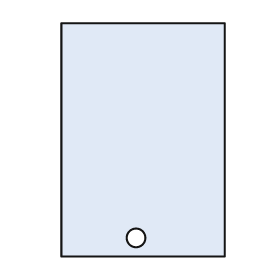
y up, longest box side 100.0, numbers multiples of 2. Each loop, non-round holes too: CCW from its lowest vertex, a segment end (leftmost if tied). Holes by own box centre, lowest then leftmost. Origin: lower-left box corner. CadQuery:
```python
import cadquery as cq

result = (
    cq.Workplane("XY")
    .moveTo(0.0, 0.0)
    .lineTo(70.0, 0.0)
    .lineTo(70.0, 100.0)
    .lineTo(0.0, 100.0)
    .close()
    .moveTo(32.0, 8.0)
    .circle(4.0)
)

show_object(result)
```